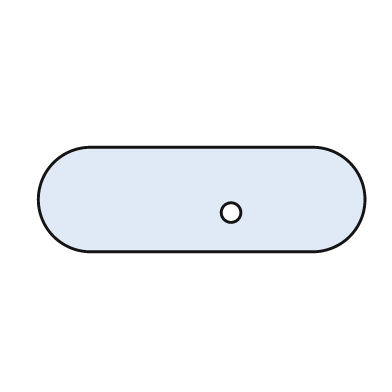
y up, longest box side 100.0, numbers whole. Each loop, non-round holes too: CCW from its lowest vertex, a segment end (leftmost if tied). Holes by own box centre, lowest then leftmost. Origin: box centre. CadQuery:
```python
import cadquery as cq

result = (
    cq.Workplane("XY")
    .moveTo(-34.0, -16.0)
    .lineTo(34.0, -16.0)
    .threePointArc((50.0, 0.0), (34.0, 16.0))
    .lineTo(-34.0, 16.0)
    .threePointArc((-50.0, 0.0), (-34.0, -16.0))
    .close()
    .moveTo(9.0, -4.0)
    .circle(3.0)
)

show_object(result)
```